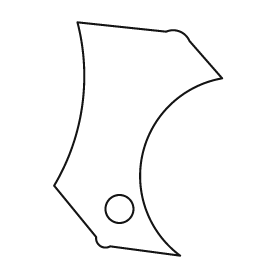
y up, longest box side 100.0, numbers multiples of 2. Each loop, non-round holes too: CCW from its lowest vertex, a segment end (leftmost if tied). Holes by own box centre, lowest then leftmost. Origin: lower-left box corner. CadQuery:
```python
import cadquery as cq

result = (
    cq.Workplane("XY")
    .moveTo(54.0, 0.0)
    .threePointArc((38.0, 44.0), (72.0, 76.0))
    .lineTo(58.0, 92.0)
    .threePointArc((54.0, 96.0), (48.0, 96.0))
    .lineTo(10.0, 100.0)
    .threePointArc((12.0, 64.0), (0.0, 30.0))
    .lineTo(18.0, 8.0)
    .threePointArc((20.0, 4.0), (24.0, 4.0))
    .close()
    .moveTo(28.0, 20.0)
    .circle(6.0)
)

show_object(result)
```